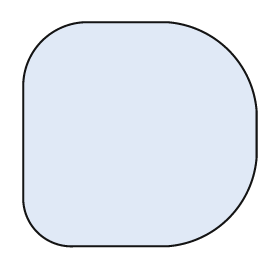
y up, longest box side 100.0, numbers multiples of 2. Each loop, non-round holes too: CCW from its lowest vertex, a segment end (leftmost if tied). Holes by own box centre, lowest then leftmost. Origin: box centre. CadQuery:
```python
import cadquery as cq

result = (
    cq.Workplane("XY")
    .moveTo(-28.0, -48.0)
    .lineTo(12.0, -48.0)
    .threePointArc((38.0, -36.0), (50.0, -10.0))
    .lineTo(50.0, 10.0)
    .threePointArc((38.0, 36.0), (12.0, 48.0))
    .lineTo(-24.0, 48.0)
    .threePointArc((-42.0, 40.0), (-50.0, 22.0))
    .lineTo(-50.0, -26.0)
    .threePointArc((-44.0, -42.0), (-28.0, -48.0))
    .close()
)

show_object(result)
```